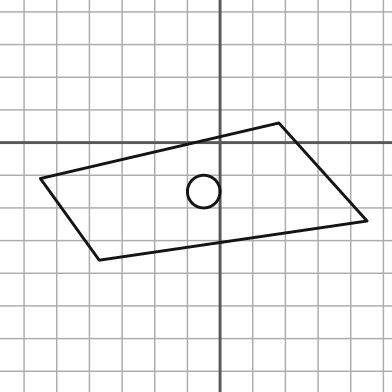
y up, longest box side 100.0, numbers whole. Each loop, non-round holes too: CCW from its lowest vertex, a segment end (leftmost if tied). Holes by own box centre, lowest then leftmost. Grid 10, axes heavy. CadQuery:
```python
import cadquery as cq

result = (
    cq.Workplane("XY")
    .moveTo(-37.0, -36.0)
    .lineTo(45.0, -24.0)
    .lineTo(18.0, 6.0)
    .lineTo(-55.0, -11.0)
    .close()
    .moveTo(-5.0, -15.0)
    .circle(5.0)
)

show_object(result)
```